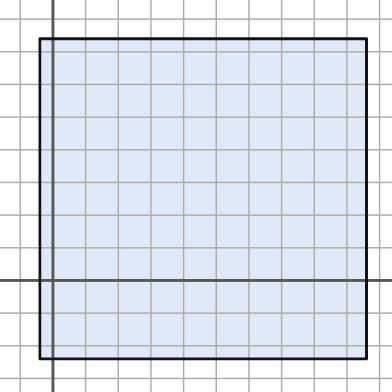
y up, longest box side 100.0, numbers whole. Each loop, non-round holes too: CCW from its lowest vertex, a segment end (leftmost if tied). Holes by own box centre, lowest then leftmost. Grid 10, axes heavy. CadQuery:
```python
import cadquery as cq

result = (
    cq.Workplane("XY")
    .moveTo(-4.0, -24.0)
    .lineTo(96.0, -24.0)
    .lineTo(96.0, 74.0)
    .lineTo(-4.0, 74.0)
    .close()
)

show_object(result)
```